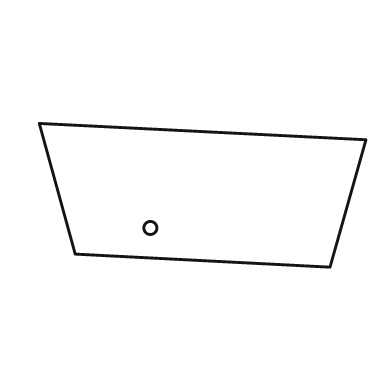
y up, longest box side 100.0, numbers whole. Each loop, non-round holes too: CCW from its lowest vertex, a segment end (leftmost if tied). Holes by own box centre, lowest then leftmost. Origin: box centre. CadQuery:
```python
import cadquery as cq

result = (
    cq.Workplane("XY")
    .moveTo(39.0, -22.0)
    .lineTo(50.0, 17.0)
    .lineTo(-50.0, 22.0)
    .lineTo(-39.0, -18.0)
    .close()
    .moveTo(-16.0, -10.0)
    .circle(2.0)
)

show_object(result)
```